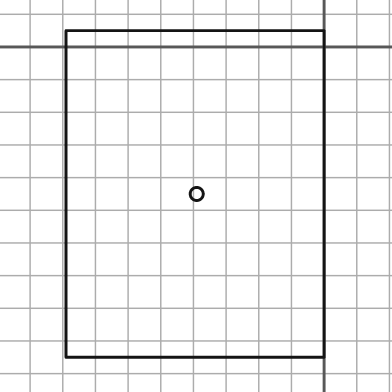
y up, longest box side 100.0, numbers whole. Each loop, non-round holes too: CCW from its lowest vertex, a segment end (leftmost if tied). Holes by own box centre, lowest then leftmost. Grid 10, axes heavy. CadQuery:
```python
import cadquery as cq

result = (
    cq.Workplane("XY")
    .moveTo(-79.0, -95.0)
    .lineTo(0.0, -95.0)
    .lineTo(0.0, 5.0)
    .lineTo(-79.0, 5.0)
    .close()
    .moveTo(-39.0, -45.0)
    .circle(2.0)
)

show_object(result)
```